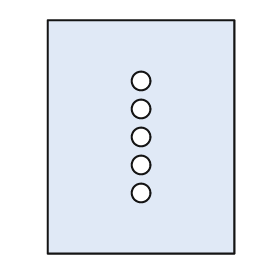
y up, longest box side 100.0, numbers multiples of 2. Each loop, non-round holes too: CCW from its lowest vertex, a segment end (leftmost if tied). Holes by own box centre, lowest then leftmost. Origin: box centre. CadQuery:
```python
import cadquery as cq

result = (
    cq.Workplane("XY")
    .moveTo(-40.0, -50.0)
    .lineTo(40.0, -50.0)
    .lineTo(40.0, 50.0)
    .lineTo(-40.0, 50.0)
    .close()
    .moveTo(0.0, -24.0)
    .circle(4.0)
    .moveTo(0.0, -12.0)
    .circle(4.0)
    .moveTo(0.0, 0.0)
    .circle(4.0)
    .moveTo(0.0, 12.0)
    .circle(4.0)
    .moveTo(0.0, 24.0)
    .circle(4.0)
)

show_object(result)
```